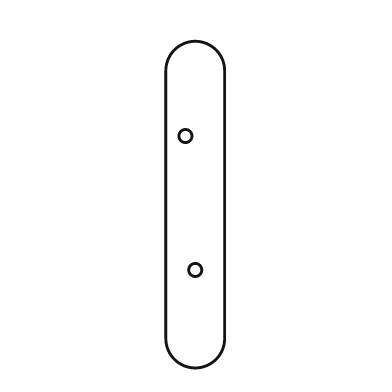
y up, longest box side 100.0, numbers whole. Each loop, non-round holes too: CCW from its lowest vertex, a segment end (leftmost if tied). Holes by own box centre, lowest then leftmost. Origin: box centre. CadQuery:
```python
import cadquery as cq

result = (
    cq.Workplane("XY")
    .moveTo(-9.0, -41.0)
    .threePointArc((0.0, -50.0), (9.0, -41.0))
    .lineTo(9.0, 41.0)
    .threePointArc((0.0, 50.0), (-9.0, 41.0))
    .close()
    .moveTo(0.0, -20.0)
    .circle(2.0)
    .moveTo(-3.0, 21.0)
    .circle(2.0)
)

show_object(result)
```